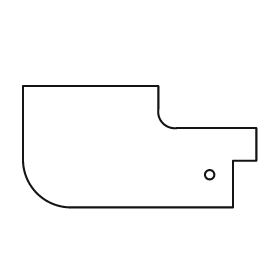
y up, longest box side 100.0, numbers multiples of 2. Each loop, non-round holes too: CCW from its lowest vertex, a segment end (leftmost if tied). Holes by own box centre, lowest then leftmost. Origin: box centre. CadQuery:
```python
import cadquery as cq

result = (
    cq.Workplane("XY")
    .moveTo(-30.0, -26.0)
    .lineTo(40.0, -26.0)
    .lineTo(40.0, -6.0)
    .lineTo(50.0, -6.0)
    .lineTo(50.0, 8.0)
    .lineTo(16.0, 8.0)
    .threePointArc((10.0, 10.0), (8.0, 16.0))
    .lineTo(8.0, 26.0)
    .lineTo(-50.0, 26.0)
    .lineTo(-50.0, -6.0)
    .threePointArc((-44.0, -20.0), (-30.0, -26.0))
    .close()
    .moveTo(30.0, -12.0)
    .circle(2.0)
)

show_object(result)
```